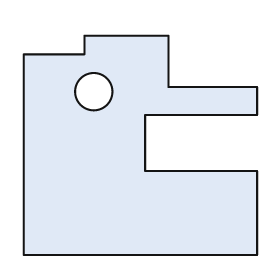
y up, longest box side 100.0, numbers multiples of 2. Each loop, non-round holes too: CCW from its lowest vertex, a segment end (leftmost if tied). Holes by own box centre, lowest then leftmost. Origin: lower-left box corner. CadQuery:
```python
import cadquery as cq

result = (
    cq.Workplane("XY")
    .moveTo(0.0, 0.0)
    .lineTo(100.0, 0.0)
    .lineTo(100.0, 36.0)
    .lineTo(52.0, 36.0)
    .lineTo(52.0, 60.0)
    .lineTo(100.0, 60.0)
    .lineTo(100.0, 72.0)
    .lineTo(62.0, 72.0)
    .lineTo(62.0, 94.0)
    .lineTo(26.0, 94.0)
    .lineTo(26.0, 86.0)
    .lineTo(0.0, 86.0)
    .close()
    .moveTo(30.0, 70.0)
    .circle(8.0)
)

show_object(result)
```